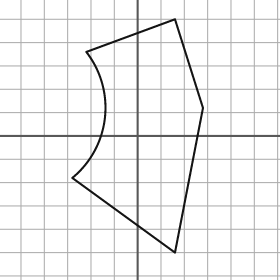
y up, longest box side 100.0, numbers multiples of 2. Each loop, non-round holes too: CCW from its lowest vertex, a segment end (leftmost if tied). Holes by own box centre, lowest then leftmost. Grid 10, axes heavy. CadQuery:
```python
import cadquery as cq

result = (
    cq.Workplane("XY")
    .moveTo(16.0, -50.0)
    .lineTo(28.0, 12.0)
    .lineTo(16.0, 50.0)
    .lineTo(-22.0, 36.0)
    .threePointArc((-14.0, 8.0), (-28.0, -18.0))
    .close()
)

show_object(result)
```